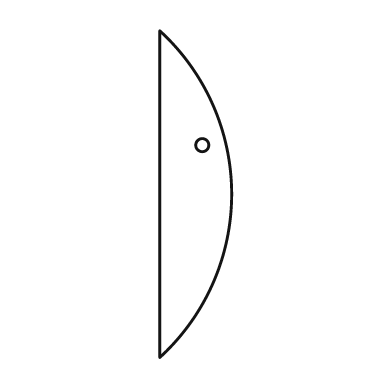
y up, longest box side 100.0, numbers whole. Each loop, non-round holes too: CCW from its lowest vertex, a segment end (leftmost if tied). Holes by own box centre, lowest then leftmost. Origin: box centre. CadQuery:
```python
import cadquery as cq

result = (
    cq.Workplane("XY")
    .moveTo(-11.0, -50.0)
    .threePointArc((11.0, 0.0), (-11.0, 50.0))
    .close()
    .moveTo(2.0, 15.0)
    .circle(2.0)
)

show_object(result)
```